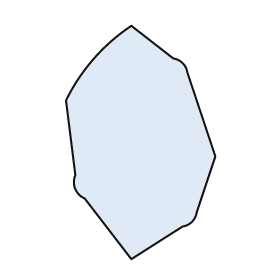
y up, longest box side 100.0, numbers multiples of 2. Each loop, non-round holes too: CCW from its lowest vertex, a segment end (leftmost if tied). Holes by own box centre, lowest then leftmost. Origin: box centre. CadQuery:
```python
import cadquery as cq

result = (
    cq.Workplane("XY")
    .moveTo(-4.0, -50.0)
    .lineTo(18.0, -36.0)
    .threePointArc((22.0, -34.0), (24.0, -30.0))
    .lineTo(32.0, -6.0)
    .lineTo(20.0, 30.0)
    .threePointArc((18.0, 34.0), (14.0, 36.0))
    .lineTo(-4.0, 50.0)
    .threePointArc((-20.0, 36.0), (-32.0, 18.0))
    .lineTo(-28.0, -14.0)
    .threePointArc((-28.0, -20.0), (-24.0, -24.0))
    .close()
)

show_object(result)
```